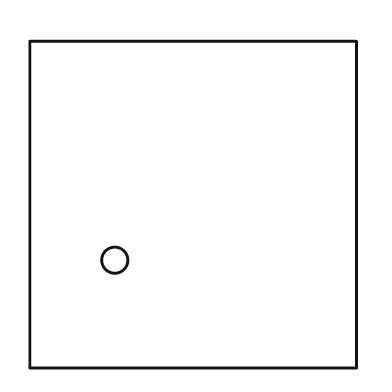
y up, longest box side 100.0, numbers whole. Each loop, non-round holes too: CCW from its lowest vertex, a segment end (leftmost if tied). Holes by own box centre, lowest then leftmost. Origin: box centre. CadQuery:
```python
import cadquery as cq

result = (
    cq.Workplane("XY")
    .moveTo(-50.0, -50.0)
    .lineTo(50.0, -50.0)
    .lineTo(50.0, 50.0)
    .lineTo(-50.0, 50.0)
    .close()
    .moveTo(-24.0, -17.0)
    .circle(4.0)
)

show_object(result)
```